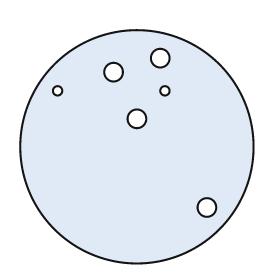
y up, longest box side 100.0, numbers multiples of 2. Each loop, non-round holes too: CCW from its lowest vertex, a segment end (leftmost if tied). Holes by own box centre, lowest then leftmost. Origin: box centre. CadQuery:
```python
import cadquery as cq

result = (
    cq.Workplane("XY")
    .moveTo(0.0, 0.0)
    .circle(50.0)
    .moveTo(30.0, -26.0)
    .circle(4.0)
    .moveTo(0.0, 12.0)
    .circle(4.0)
    .moveTo(-34.0, 24.0)
    .circle(2.0)
    .moveTo(12.0, 24.0)
    .circle(2.0)
    .moveTo(-10.0, 32.0)
    .circle(4.0)
    .moveTo(10.0, 38.0)
    .circle(4.0)
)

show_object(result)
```